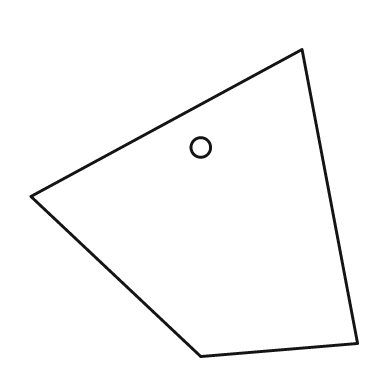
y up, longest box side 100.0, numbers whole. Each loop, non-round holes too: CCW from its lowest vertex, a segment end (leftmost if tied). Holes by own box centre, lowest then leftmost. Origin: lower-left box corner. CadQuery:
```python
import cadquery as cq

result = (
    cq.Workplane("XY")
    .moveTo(52.0, 0.0)
    .lineTo(100.0, 4.0)
    .lineTo(83.0, 94.0)
    .lineTo(0.0, 49.0)
    .close()
    .moveTo(52.0, 64.0)
    .circle(3.0)
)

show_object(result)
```